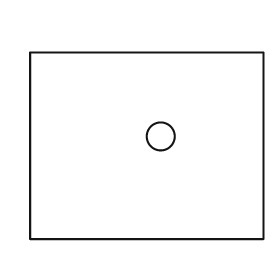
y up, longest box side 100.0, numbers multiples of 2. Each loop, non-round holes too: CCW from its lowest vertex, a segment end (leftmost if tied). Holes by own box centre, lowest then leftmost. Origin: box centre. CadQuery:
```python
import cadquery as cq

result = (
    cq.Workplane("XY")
    .moveTo(-50.0, -40.0)
    .lineTo(50.0, -40.0)
    .lineTo(50.0, 40.0)
    .lineTo(-50.0, 40.0)
    .close()
    .moveTo(6.0, 4.0)
    .circle(6.0)
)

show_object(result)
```